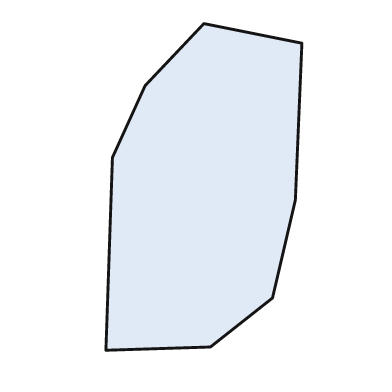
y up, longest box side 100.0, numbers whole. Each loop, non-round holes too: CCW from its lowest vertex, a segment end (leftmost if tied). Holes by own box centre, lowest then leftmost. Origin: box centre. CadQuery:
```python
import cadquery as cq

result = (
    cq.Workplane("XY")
    .moveTo(-30.0, -50.0)
    .lineTo(2.0, -49.0)
    .lineTo(21.0, -34.0)
    .lineTo(28.0, -4.0)
    .lineTo(30.0, 44.0)
    .lineTo(0.0, 50.0)
    .lineTo(-18.0, 31.0)
    .lineTo(-28.0, 9.0)
    .close()
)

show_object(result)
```